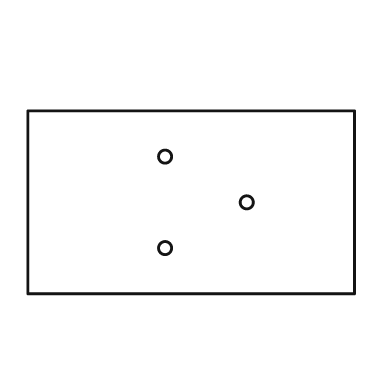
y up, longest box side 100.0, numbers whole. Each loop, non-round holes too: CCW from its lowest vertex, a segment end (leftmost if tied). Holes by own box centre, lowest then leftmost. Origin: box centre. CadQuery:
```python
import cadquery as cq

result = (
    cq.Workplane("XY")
    .moveTo(-50.0, -28.0)
    .lineTo(50.0, -28.0)
    .lineTo(50.0, 28.0)
    .lineTo(-50.0, 28.0)
    .close()
    .moveTo(-8.0, -14.0)
    .circle(2.0)
    .moveTo(17.0, 0.0)
    .circle(2.0)
    .moveTo(-8.0, 14.0)
    .circle(2.0)
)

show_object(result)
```